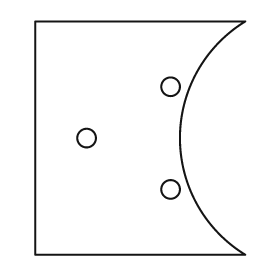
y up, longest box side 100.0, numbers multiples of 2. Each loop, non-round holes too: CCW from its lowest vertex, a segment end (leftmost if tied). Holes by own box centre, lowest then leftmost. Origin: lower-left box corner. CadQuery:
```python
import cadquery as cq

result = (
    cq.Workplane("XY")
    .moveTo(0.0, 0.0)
    .lineTo(90.0, 0.0)
    .threePointArc((62.0, 50.0), (90.0, 100.0))
    .lineTo(0.0, 100.0)
    .close()
    .moveTo(58.0, 28.0)
    .circle(4.0)
    .moveTo(22.0, 50.0)
    .circle(4.0)
    .moveTo(58.0, 72.0)
    .circle(4.0)
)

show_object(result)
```